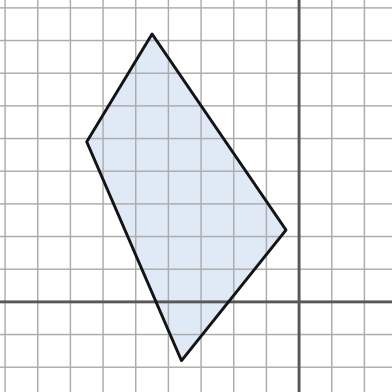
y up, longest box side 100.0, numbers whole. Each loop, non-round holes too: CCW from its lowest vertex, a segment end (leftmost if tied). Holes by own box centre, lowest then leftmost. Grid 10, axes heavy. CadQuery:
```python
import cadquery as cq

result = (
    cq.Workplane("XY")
    .moveTo(-36.0, -18.0)
    .lineTo(-4.0, 22.0)
    .lineTo(-45.0, 82.0)
    .lineTo(-65.0, 49.0)
    .close()
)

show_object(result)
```